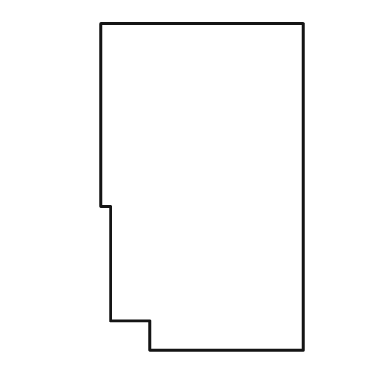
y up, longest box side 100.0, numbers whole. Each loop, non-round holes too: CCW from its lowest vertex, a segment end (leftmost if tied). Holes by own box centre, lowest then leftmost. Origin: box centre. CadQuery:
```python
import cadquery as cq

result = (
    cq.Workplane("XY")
    .moveTo(-16.0, -50.0)
    .lineTo(31.0, -50.0)
    .lineTo(31.0, 50.0)
    .lineTo(-31.0, 50.0)
    .lineTo(-31.0, -6.0)
    .lineTo(-28.0, -6.0)
    .lineTo(-28.0, -41.0)
    .lineTo(-16.0, -41.0)
    .close()
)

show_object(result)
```